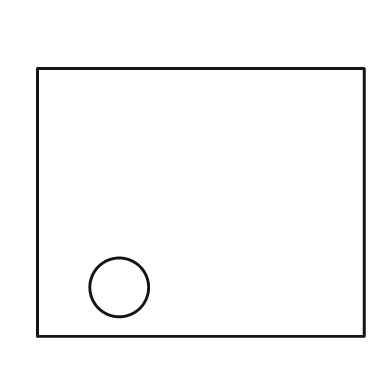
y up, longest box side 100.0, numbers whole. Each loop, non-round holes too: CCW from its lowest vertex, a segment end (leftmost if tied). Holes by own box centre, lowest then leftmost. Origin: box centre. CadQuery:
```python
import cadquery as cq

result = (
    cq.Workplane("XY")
    .moveTo(-50.0, -41.0)
    .lineTo(50.0, -41.0)
    .lineTo(50.0, 41.0)
    .lineTo(-50.0, 41.0)
    .close()
    .moveTo(-25.0, -26.0)
    .circle(9.0)
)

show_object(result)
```